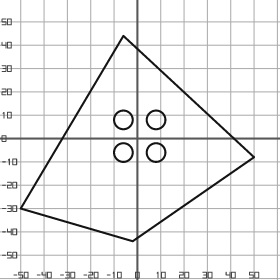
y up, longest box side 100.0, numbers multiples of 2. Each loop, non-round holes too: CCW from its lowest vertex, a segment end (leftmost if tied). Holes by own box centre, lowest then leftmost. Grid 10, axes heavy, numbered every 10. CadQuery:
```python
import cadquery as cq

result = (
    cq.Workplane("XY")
    .moveTo(-2.0, -44.0)
    .lineTo(50.0, -8.0)
    .lineTo(-6.0, 44.0)
    .lineTo(-50.0, -30.0)
    .close()
    .moveTo(-6.0, -6.0)
    .circle(4.0)
    .moveTo(8.0, -6.0)
    .circle(4.0)
    .moveTo(-6.0, 8.0)
    .circle(4.0)
    .moveTo(8.0, 8.0)
    .circle(4.0)
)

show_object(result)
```